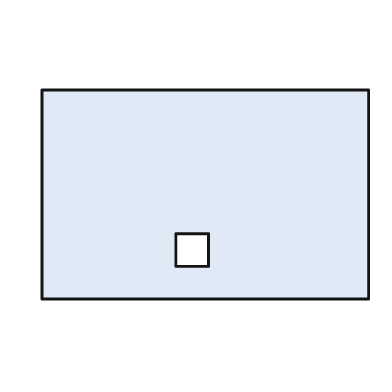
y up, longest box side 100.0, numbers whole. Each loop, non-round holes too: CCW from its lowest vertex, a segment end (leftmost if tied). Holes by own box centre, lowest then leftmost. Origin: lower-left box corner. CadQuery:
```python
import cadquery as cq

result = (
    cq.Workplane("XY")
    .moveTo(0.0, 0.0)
    .lineTo(100.0, 0.0)
    .lineTo(100.0, 64.0)
    .lineTo(0.0, 64.0)
    .close()
    .moveTo(41.0, 10.0)
    .lineTo(51.0, 10.0)
    .lineTo(51.0, 20.0)
    .lineTo(41.0, 20.0)
    .close()
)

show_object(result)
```